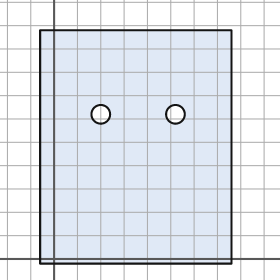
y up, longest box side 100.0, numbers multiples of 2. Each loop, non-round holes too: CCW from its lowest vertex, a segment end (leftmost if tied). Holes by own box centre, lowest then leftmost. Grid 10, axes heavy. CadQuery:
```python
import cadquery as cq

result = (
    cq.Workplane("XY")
    .moveTo(-6.0, -2.0)
    .lineTo(76.0, -2.0)
    .lineTo(76.0, 98.0)
    .lineTo(-6.0, 98.0)
    .close()
    .moveTo(20.0, 62.0)
    .circle(4.0)
    .moveTo(52.0, 62.0)
    .circle(4.0)
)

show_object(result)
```